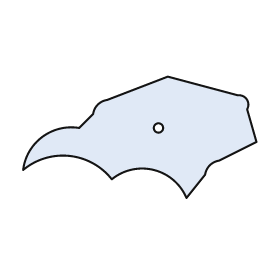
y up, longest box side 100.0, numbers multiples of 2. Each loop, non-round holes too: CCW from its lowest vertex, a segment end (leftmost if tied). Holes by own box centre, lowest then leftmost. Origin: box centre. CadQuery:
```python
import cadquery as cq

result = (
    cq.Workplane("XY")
    .moveTo(20.0, -26.0)
    .lineTo(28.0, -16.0)
    .threePointArc((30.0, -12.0), (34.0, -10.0))
    .lineTo(50.0, -2.0)
    .lineTo(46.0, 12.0)
    .threePointArc((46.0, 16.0), (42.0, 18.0))
    .lineTo(12.0, 26.0)
    .lineTo(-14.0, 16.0)
    .threePointArc((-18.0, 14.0), (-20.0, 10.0))
    .lineTo(-26.0, 4.0)
    .threePointArc((-42.0, 0.0), (-50.0, -14.0))
    .threePointArc((-30.0, -8.0), (-12.0, -18.0))
    .threePointArc((6.0, -14.0), (20.0, -26.0))
    .close()
    .moveTo(8.0, 4.0)
    .circle(2.0)
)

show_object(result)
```